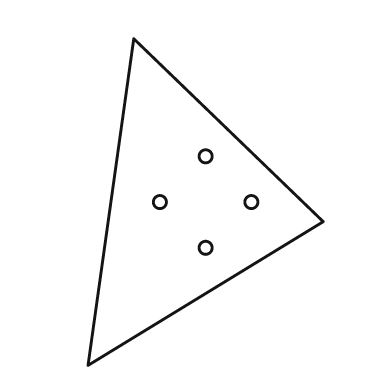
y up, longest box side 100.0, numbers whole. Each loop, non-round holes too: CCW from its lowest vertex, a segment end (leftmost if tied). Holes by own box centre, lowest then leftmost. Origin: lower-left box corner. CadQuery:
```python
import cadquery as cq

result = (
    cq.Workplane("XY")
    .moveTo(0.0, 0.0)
    .lineTo(72.0, 44.0)
    .lineTo(14.0, 100.0)
    .close()
    .moveTo(36.0, 36.0)
    .circle(2.0)
    .moveTo(22.0, 50.0)
    .circle(2.0)
    .moveTo(50.0, 50.0)
    .circle(2.0)
    .moveTo(36.0, 64.0)
    .circle(2.0)
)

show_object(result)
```